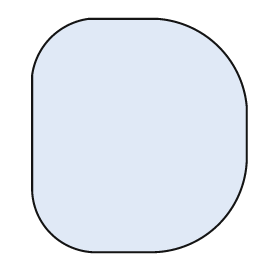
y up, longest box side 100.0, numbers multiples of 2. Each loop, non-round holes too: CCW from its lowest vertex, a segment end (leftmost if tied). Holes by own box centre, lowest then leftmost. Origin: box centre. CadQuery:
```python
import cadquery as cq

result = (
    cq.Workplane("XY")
    .moveTo(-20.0, -50.0)
    .lineTo(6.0, -50.0)
    .threePointArc((34.0, -38.0), (46.0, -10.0))
    .lineTo(46.0, 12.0)
    .threePointArc((34.0, 38.0), (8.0, 50.0))
    .lineTo(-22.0, 50.0)
    .threePointArc((-38.0, 42.0), (-46.0, 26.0))
    .lineTo(-46.0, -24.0)
    .threePointArc((-38.0, -42.0), (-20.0, -50.0))
    .close()
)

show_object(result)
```